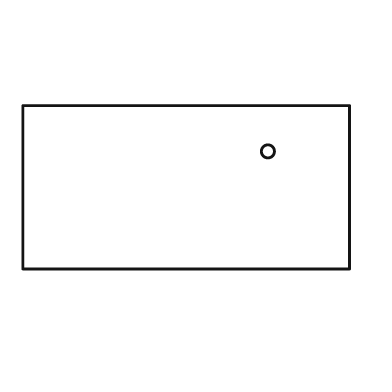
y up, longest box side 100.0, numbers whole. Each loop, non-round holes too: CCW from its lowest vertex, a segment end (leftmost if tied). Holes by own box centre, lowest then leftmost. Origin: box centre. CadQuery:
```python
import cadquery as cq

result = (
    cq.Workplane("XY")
    .moveTo(-50.0, -25.0)
    .lineTo(50.0, -25.0)
    .lineTo(50.0, 25.0)
    .lineTo(-50.0, 25.0)
    .close()
    .moveTo(25.0, 11.0)
    .circle(2.0)
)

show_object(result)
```